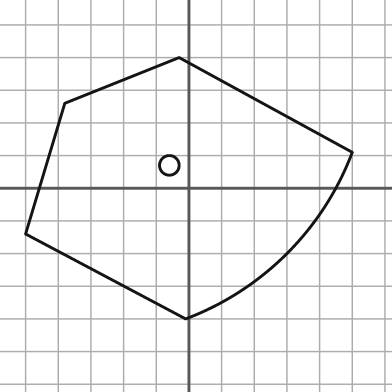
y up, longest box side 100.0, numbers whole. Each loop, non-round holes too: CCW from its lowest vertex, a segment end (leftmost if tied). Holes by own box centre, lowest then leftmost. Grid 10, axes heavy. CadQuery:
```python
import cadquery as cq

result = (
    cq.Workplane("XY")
    .moveTo(-1.0, -40.0)
    .threePointArc((30.0, -20.0), (50.0, 11.0))
    .lineTo(-3.0, 40.0)
    .lineTo(-38.0, 26.0)
    .lineTo(-50.0, -14.0)
    .close()
    .moveTo(-6.0, 7.0)
    .circle(3.0)
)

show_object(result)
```